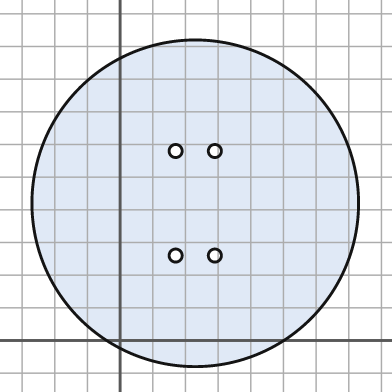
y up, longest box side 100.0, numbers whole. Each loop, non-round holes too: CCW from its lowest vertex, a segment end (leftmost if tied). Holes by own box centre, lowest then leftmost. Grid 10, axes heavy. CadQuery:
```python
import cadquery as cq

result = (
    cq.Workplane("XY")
    .moveTo(23.0, 42.0)
    .circle(50.0)
    .moveTo(17.0, 26.0)
    .circle(2.0)
    .moveTo(29.0, 26.0)
    .circle(2.0)
    .moveTo(17.0, 58.0)
    .circle(2.0)
    .moveTo(29.0, 58.0)
    .circle(2.0)
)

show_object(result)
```